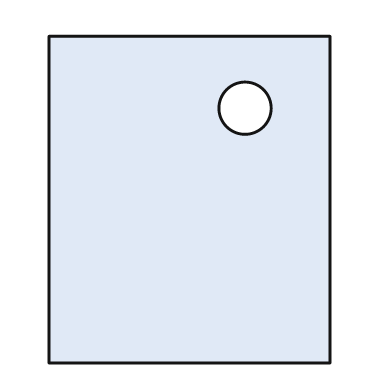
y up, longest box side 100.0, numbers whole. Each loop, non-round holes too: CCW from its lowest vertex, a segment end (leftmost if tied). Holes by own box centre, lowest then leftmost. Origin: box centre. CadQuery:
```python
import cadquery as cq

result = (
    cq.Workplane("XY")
    .moveTo(-43.0, -50.0)
    .lineTo(43.0, -50.0)
    .lineTo(43.0, 50.0)
    .lineTo(-43.0, 50.0)
    .close()
    .moveTo(17.0, 28.0)
    .circle(8.0)
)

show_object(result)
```